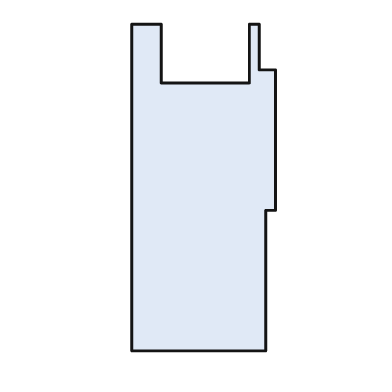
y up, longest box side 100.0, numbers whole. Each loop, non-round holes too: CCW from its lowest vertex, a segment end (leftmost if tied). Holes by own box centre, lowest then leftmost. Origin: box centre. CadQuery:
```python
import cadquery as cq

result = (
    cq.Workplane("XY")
    .moveTo(-22.0, -50.0)
    .lineTo(19.0, -50.0)
    .lineTo(19.0, -7.0)
    .lineTo(22.0, -7.0)
    .lineTo(22.0, 36.0)
    .lineTo(17.0, 36.0)
    .lineTo(17.0, 50.0)
    .lineTo(14.0, 50.0)
    .lineTo(14.0, 32.0)
    .lineTo(-13.0, 32.0)
    .lineTo(-13.0, 50.0)
    .lineTo(-22.0, 50.0)
    .close()
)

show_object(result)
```